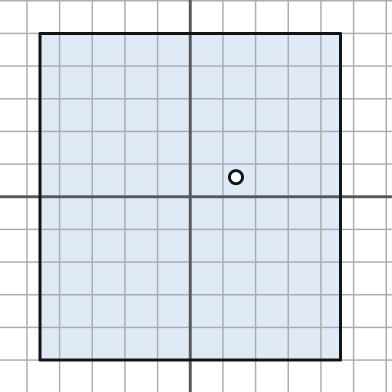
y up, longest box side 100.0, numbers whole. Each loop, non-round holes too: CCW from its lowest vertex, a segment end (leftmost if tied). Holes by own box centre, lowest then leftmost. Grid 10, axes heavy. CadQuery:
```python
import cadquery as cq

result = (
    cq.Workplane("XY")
    .moveTo(-46.0, -50.0)
    .lineTo(46.0, -50.0)
    .lineTo(46.0, 50.0)
    .lineTo(-46.0, 50.0)
    .close()
    .moveTo(14.0, 6.0)
    .circle(2.0)
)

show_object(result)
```